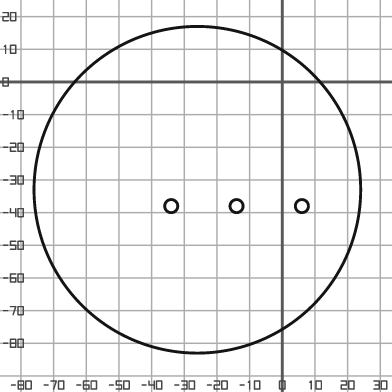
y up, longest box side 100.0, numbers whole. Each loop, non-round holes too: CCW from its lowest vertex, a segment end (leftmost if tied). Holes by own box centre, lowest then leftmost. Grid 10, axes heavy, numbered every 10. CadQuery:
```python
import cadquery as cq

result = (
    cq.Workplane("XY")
    .moveTo(-26.0, -33.0)
    .circle(50.0)
    .moveTo(-34.0, -38.0)
    .circle(2.0)
    .moveTo(-14.0, -38.0)
    .circle(2.0)
    .moveTo(6.0, -38.0)
    .circle(2.0)
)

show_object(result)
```